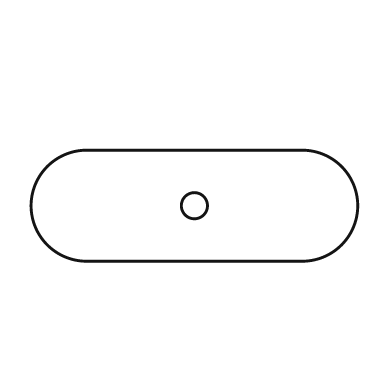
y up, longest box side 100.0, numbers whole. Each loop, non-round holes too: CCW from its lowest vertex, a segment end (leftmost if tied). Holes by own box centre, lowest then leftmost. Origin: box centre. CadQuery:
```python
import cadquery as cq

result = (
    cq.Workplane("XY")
    .moveTo(-33.0, -17.0)
    .lineTo(33.0, -17.0)
    .threePointArc((50.0, 0.0), (33.0, 17.0))
    .lineTo(-33.0, 17.0)
    .threePointArc((-50.0, 0.0), (-33.0, -17.0))
    .close()
    .moveTo(0.0, 0.0)
    .circle(4.0)
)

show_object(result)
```